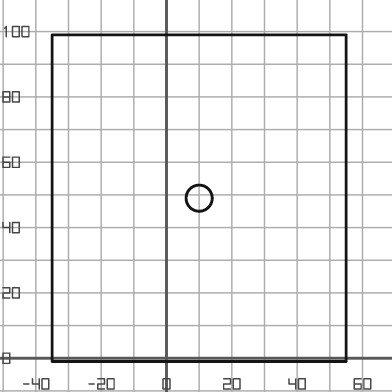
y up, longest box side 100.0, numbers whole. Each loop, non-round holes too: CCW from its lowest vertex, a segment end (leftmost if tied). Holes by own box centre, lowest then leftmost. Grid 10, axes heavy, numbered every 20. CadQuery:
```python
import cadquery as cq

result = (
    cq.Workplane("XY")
    .moveTo(-35.0, -1.0)
    .lineTo(55.0, -1.0)
    .lineTo(55.0, 99.0)
    .lineTo(-35.0, 99.0)
    .close()
    .moveTo(10.0, 49.0)
    .circle(4.0)
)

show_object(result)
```